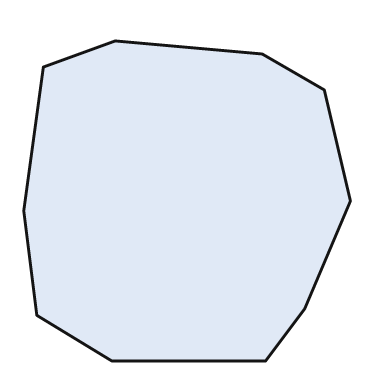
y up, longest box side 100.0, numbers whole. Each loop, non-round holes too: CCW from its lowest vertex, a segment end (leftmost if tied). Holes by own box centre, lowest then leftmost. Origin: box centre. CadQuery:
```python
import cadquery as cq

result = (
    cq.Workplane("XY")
    .moveTo(-23.0, -49.0)
    .lineTo(24.0, -49.0)
    .lineTo(36.0, -33.0)
    .lineTo(50.0, 0.0)
    .lineTo(42.0, 34.0)
    .lineTo(23.0, 45.0)
    .lineTo(-22.0, 49.0)
    .lineTo(-44.0, 41.0)
    .lineTo(-50.0, -3.0)
    .lineTo(-46.0, -35.0)
    .close()
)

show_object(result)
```